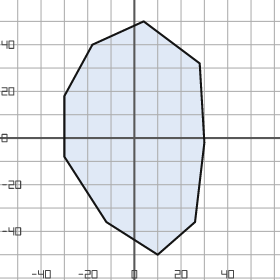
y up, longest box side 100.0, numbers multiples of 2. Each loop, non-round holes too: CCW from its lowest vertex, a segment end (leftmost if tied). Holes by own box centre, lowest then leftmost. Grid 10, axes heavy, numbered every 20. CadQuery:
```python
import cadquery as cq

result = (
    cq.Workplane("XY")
    .moveTo(10.0, -50.0)
    .lineTo(26.0, -36.0)
    .lineTo(30.0, -2.0)
    .lineTo(28.0, 32.0)
    .lineTo(4.0, 50.0)
    .lineTo(-18.0, 40.0)
    .lineTo(-30.0, 18.0)
    .lineTo(-30.0, -8.0)
    .lineTo(-12.0, -36.0)
    .close()
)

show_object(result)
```